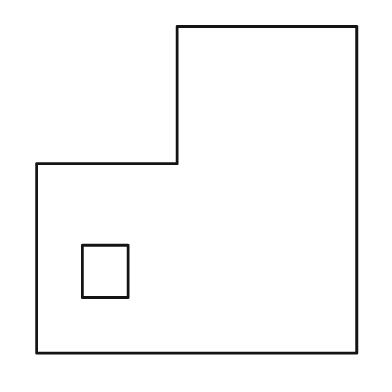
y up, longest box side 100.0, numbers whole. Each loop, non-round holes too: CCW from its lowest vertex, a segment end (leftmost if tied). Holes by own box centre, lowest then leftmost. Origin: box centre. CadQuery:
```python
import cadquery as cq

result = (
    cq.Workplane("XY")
    .moveTo(-49.0, -50.0)
    .lineTo(49.0, -50.0)
    .lineTo(49.0, 50.0)
    .lineTo(-6.0, 50.0)
    .lineTo(-6.0, 8.0)
    .lineTo(-49.0, 8.0)
    .close()
    .moveTo(-35.0, -33.0)
    .lineTo(-21.0, -33.0)
    .lineTo(-21.0, -17.0)
    .lineTo(-35.0, -17.0)
    .close()
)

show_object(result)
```